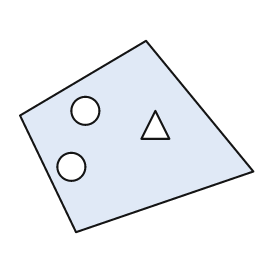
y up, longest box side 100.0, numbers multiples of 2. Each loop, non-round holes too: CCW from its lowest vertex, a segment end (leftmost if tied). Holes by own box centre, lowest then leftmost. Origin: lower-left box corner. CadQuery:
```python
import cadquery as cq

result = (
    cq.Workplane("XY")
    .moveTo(24.0, 0.0)
    .lineTo(100.0, 26.0)
    .lineTo(54.0, 82.0)
    .lineTo(0.0, 50.0)
    .close()
    .moveTo(22.0, 28.0)
    .circle(6.0)
    .moveTo(52.0, 40.0)
    .lineTo(64.0, 40.0)
    .lineTo(58.0, 52.0)
    .close()
    .moveTo(28.0, 52.0)
    .circle(6.0)
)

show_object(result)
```